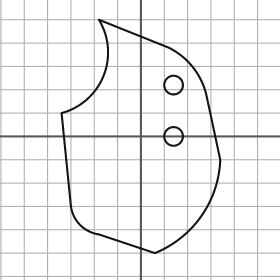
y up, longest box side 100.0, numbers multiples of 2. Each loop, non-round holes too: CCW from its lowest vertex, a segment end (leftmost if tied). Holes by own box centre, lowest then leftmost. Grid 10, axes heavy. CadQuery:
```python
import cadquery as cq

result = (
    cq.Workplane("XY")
    .moveTo(6.0, -50.0)
    .threePointArc((26.0, -34.0), (34.0, -10.0))
    .lineTo(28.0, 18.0)
    .threePointArc((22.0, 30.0), (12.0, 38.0))
    .lineTo(-18.0, 50.0)
    .threePointArc((-16.0, 26.0), (-34.0, 10.0))
    .lineTo(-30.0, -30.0)
    .threePointArc((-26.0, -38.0), (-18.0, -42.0))
    .close()
    .moveTo(14.0, 0.0)
    .circle(4.0)
    .moveTo(14.0, 22.0)
    .circle(4.0)
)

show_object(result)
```